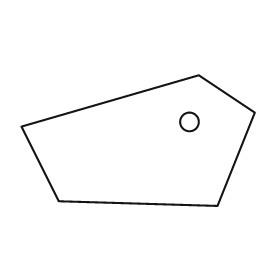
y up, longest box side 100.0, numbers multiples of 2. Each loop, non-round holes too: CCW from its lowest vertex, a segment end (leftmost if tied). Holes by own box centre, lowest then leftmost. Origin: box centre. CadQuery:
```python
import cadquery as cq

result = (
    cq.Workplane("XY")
    .moveTo(34.0, -28.0)
    .lineTo(50.0, 12.0)
    .lineTo(26.0, 28.0)
    .lineTo(-50.0, 6.0)
    .lineTo(-34.0, -26.0)
    .close()
    .moveTo(22.0, 8.0)
    .circle(4.0)
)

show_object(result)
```